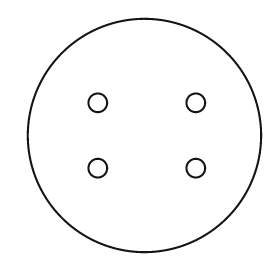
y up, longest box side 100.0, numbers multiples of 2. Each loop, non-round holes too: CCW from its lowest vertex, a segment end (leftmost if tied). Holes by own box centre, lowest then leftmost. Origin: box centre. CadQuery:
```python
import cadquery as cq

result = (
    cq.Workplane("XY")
    .moveTo(0.0, 0.0)
    .circle(50.0)
    .moveTo(-20.0, -14.0)
    .circle(4.0)
    .moveTo(22.0, -14.0)
    .circle(4.0)
    .moveTo(-20.0, 14.0)
    .circle(4.0)
    .moveTo(22.0, 14.0)
    .circle(4.0)
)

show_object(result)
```